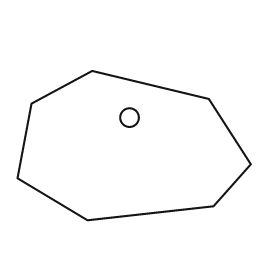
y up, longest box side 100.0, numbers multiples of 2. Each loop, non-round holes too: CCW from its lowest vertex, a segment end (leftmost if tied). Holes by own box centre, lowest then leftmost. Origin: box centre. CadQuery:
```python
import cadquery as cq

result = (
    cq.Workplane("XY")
    .moveTo(-20.0, -32.0)
    .lineTo(34.0, -26.0)
    .lineTo(50.0, -8.0)
    .lineTo(32.0, 20.0)
    .lineTo(-18.0, 32.0)
    .lineTo(-44.0, 18.0)
    .lineTo(-50.0, -14.0)
    .close()
    .moveTo(-2.0, 12.0)
    .circle(4.0)
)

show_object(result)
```